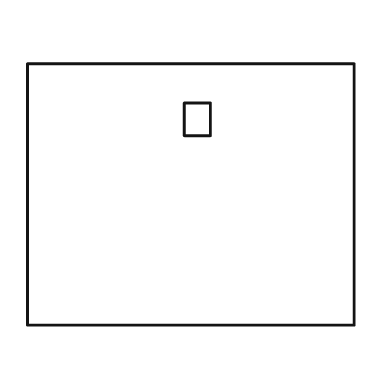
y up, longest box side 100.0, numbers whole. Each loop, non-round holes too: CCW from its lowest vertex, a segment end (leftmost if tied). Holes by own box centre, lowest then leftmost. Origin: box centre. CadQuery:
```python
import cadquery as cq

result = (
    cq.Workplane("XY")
    .moveTo(-50.0, -40.0)
    .lineTo(50.0, -40.0)
    .lineTo(50.0, 40.0)
    .lineTo(-50.0, 40.0)
    .close()
    .moveTo(-2.0, 18.0)
    .lineTo(6.0, 18.0)
    .lineTo(6.0, 28.0)
    .lineTo(-2.0, 28.0)
    .close()
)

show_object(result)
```